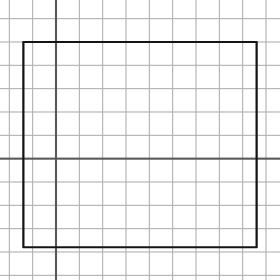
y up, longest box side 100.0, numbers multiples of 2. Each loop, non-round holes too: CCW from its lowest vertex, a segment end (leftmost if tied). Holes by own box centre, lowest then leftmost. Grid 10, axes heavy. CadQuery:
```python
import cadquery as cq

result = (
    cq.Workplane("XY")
    .moveTo(-14.0, -38.0)
    .lineTo(86.0, -38.0)
    .lineTo(86.0, 50.0)
    .lineTo(-14.0, 50.0)
    .close()
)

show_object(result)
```